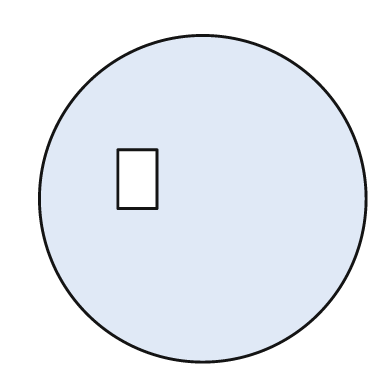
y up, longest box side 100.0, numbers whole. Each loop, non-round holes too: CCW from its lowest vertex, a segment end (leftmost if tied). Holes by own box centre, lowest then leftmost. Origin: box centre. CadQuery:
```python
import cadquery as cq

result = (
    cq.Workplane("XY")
    .moveTo(0.0, 0.0)
    .circle(50.0)
    .moveTo(-26.0, -3.0)
    .lineTo(-14.0, -3.0)
    .lineTo(-14.0, 15.0)
    .lineTo(-26.0, 15.0)
    .close()
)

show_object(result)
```